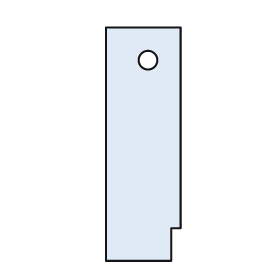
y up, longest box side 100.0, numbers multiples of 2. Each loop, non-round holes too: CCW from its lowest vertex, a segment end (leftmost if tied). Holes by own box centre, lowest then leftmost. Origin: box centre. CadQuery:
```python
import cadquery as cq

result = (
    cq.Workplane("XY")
    .moveTo(-16.0, -50.0)
    .lineTo(12.0, -50.0)
    .lineTo(12.0, -36.0)
    .lineTo(16.0, -36.0)
    .lineTo(16.0, 50.0)
    .lineTo(-16.0, 50.0)
    .close()
    .moveTo(2.0, 36.0)
    .circle(4.0)
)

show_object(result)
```